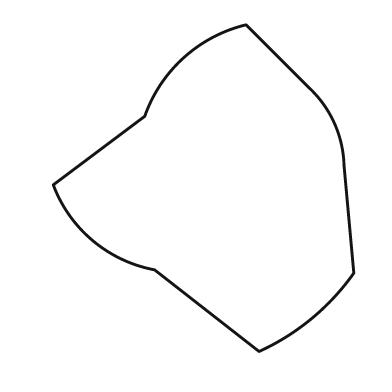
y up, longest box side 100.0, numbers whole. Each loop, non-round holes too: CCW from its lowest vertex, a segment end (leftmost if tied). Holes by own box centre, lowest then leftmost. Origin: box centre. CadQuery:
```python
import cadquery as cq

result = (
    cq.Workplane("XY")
    .moveTo(17.0, -50.0)
    .threePointArc((33.0, -40.0), (46.0, -26.0))
    .lineTo(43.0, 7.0)
    .threePointArc((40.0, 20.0), (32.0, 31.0))
    .lineTo(13.0, 50.0)
    .threePointArc((-6.0, 40.0), (-18.0, 22.0))
    .lineTo(-46.0, 1.0)
    .threePointArc((-34.0, -16.0), (-15.0, -25.0))
    .close()
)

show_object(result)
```